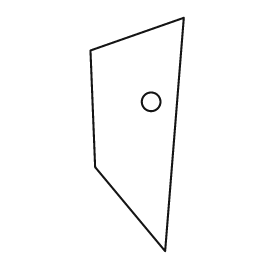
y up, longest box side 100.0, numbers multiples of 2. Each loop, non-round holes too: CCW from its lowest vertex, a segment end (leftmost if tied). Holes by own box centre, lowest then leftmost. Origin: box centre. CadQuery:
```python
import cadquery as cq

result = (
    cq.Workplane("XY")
    .moveTo(12.0, -50.0)
    .lineTo(20.0, 50.0)
    .lineTo(-20.0, 36.0)
    .lineTo(-18.0, -14.0)
    .close()
    .moveTo(6.0, 14.0)
    .circle(4.0)
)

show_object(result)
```